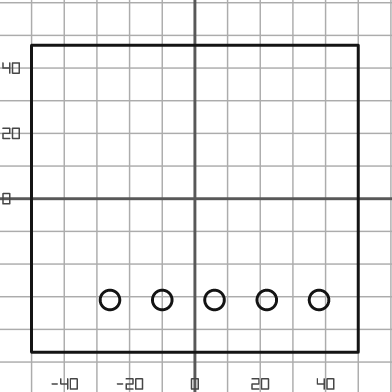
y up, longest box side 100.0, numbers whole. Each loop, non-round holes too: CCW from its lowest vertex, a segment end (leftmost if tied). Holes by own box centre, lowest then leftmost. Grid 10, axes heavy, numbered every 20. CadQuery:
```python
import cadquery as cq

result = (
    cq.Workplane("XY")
    .moveTo(-50.0, -47.0)
    .lineTo(50.0, -47.0)
    .lineTo(50.0, 47.0)
    .lineTo(-50.0, 47.0)
    .close()
    .moveTo(-26.0, -31.0)
    .circle(3.0)
    .moveTo(-10.0, -31.0)
    .circle(3.0)
    .moveTo(6.0, -31.0)
    .circle(3.0)
    .moveTo(22.0, -31.0)
    .circle(3.0)
    .moveTo(38.0, -31.0)
    .circle(3.0)
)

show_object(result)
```